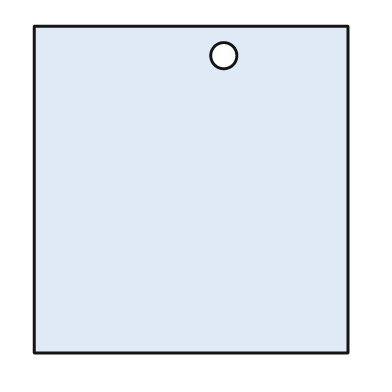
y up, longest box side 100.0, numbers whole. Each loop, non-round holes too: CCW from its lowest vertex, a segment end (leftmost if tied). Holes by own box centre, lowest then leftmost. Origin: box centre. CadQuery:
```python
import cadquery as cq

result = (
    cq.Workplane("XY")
    .moveTo(-48.0, -50.0)
    .lineTo(48.0, -50.0)
    .lineTo(48.0, 50.0)
    .lineTo(-48.0, 50.0)
    .close()
    .moveTo(10.0, 41.0)
    .circle(4.0)
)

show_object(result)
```